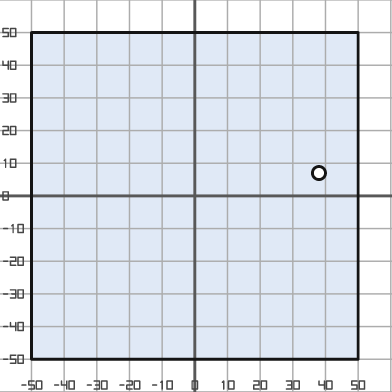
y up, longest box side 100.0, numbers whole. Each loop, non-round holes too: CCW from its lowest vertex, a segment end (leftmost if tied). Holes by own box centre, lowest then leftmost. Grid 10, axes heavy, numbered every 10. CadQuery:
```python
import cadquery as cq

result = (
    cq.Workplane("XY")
    .moveTo(-50.0, -50.0)
    .lineTo(50.0, -50.0)
    .lineTo(50.0, 50.0)
    .lineTo(-50.0, 50.0)
    .close()
    .moveTo(38.0, 7.0)
    .circle(2.0)
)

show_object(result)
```